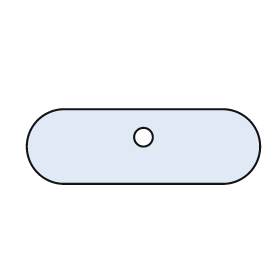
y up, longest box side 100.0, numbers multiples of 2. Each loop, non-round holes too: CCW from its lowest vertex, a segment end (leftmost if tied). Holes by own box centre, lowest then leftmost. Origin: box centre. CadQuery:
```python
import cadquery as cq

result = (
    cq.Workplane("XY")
    .moveTo(-34.0, -16.0)
    .lineTo(34.0, -16.0)
    .threePointArc((50.0, 0.0), (34.0, 16.0))
    .lineTo(-34.0, 16.0)
    .threePointArc((-50.0, 0.0), (-34.0, -16.0))
    .close()
    .moveTo(0.0, 4.0)
    .circle(4.0)
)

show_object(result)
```